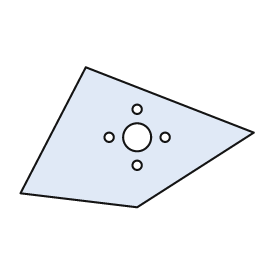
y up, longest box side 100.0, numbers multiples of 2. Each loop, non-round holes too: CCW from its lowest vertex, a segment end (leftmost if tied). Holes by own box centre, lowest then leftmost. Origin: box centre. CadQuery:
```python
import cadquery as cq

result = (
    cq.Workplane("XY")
    .moveTo(0.0, -30.0)
    .lineTo(50.0, 2.0)
    .lineTo(-22.0, 30.0)
    .lineTo(-50.0, -24.0)
    .close()
    .moveTo(0.0, -12.0)
    .circle(2.0)
    .moveTo(-12.0, 0.0)
    .circle(2.0)
    .moveTo(0.0, 0.0)
    .circle(6.0)
    .moveTo(12.0, 0.0)
    .circle(2.0)
    .moveTo(0.0, 12.0)
    .circle(2.0)
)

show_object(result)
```